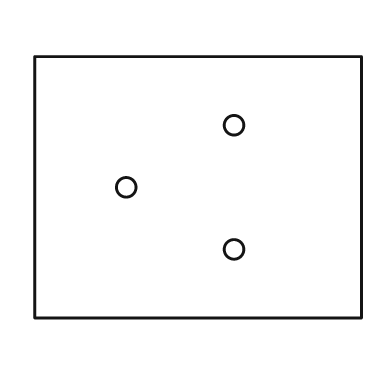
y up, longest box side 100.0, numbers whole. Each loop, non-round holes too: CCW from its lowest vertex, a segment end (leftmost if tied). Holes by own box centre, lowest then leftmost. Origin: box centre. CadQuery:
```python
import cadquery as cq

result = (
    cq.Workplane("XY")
    .moveTo(-50.0, -40.0)
    .lineTo(50.0, -40.0)
    .lineTo(50.0, 40.0)
    .lineTo(-50.0, 40.0)
    .close()
    .moveTo(11.0, -19.0)
    .circle(3.0)
    .moveTo(-22.0, 0.0)
    .circle(3.0)
    .moveTo(11.0, 19.0)
    .circle(3.0)
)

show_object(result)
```